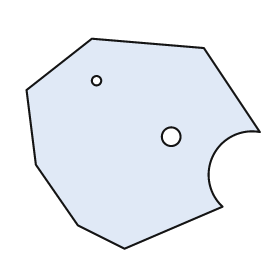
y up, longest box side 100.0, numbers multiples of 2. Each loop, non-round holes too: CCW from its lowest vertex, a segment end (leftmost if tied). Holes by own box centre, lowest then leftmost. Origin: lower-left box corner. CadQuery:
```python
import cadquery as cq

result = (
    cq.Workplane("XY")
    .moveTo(42.0, 0.0)
    .lineTo(84.0, 18.0)
    .threePointArc((80.0, 40.0), (100.0, 50.0))
    .lineTo(76.0, 86.0)
    .lineTo(28.0, 90.0)
    .lineTo(0.0, 68.0)
    .lineTo(4.0, 36.0)
    .lineTo(22.0, 10.0)
    .close()
    .moveTo(62.0, 48.0)
    .circle(4.0)
    .moveTo(30.0, 72.0)
    .circle(2.0)
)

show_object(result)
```